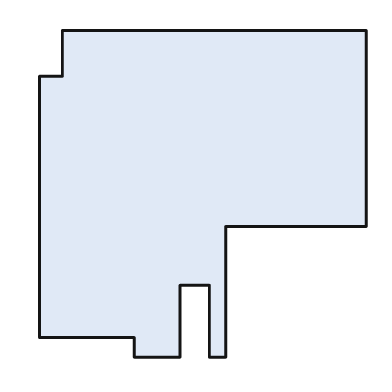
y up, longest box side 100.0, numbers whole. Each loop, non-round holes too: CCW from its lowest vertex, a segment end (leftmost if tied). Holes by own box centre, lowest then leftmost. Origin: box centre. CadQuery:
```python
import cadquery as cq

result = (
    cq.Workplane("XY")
    .moveTo(-21.0, -50.0)
    .lineTo(-7.0, -50.0)
    .lineTo(-7.0, -28.0)
    .lineTo(2.0, -28.0)
    .lineTo(2.0, -50.0)
    .lineTo(7.0, -50.0)
    .lineTo(7.0, -10.0)
    .lineTo(50.0, -10.0)
    .lineTo(50.0, 50.0)
    .lineTo(-43.0, 50.0)
    .lineTo(-43.0, 36.0)
    .lineTo(-50.0, 36.0)
    .lineTo(-50.0, -44.0)
    .lineTo(-21.0, -44.0)
    .close()
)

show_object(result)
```